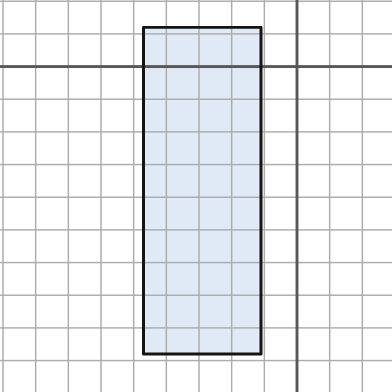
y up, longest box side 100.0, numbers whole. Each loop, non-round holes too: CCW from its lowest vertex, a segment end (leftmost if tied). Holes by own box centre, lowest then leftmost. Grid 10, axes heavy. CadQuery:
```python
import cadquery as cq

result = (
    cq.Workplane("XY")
    .moveTo(-47.0, -88.0)
    .lineTo(-11.0, -88.0)
    .lineTo(-11.0, 12.0)
    .lineTo(-47.0, 12.0)
    .close()
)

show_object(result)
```